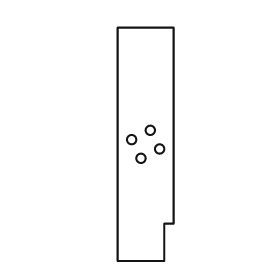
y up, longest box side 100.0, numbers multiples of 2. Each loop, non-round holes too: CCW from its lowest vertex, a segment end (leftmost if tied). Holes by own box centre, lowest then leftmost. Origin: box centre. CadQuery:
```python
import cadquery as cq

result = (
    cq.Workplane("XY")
    .moveTo(-12.0, -50.0)
    .lineTo(8.0, -50.0)
    .lineTo(8.0, -34.0)
    .lineTo(12.0, -34.0)
    .lineTo(12.0, 50.0)
    .lineTo(-12.0, 50.0)
    .close()
    .moveTo(-2.0, -6.0)
    .circle(2.0)
    .moveTo(6.0, -2.0)
    .circle(2.0)
    .moveTo(-6.0, 2.0)
    .circle(2.0)
    .moveTo(2.0, 6.0)
    .circle(2.0)
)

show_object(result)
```